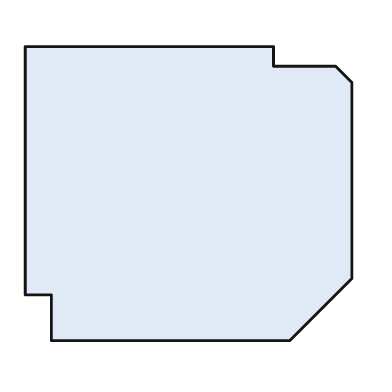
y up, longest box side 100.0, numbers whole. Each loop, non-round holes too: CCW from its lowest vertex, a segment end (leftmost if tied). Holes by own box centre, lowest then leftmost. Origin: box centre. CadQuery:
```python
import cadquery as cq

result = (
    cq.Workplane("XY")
    .moveTo(-42.0, -45.0)
    .lineTo(31.0, -45.0)
    .lineTo(50.0, -26.0)
    .lineTo(50.0, 34.0)
    .lineTo(45.0, 39.0)
    .lineTo(26.0, 39.0)
    .lineTo(26.0, 45.0)
    .lineTo(-50.0, 45.0)
    .lineTo(-50.0, -31.0)
    .lineTo(-42.0, -31.0)
    .close()
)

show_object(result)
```